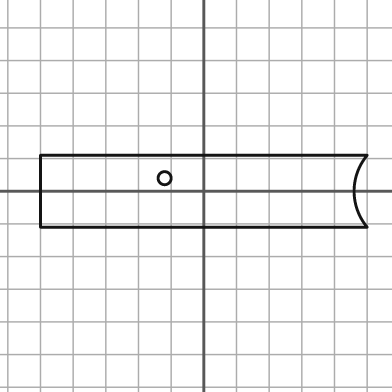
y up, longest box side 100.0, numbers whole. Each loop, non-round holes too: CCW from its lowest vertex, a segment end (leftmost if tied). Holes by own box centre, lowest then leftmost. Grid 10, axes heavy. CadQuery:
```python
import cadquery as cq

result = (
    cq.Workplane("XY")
    .moveTo(-50.0, -11.0)
    .lineTo(50.0, -11.0)
    .threePointArc((46.0, 0.0), (50.0, 11.0))
    .lineTo(-50.0, 11.0)
    .close()
    .moveTo(-12.0, 4.0)
    .circle(2.0)
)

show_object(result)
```